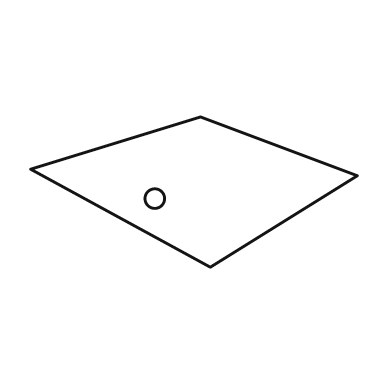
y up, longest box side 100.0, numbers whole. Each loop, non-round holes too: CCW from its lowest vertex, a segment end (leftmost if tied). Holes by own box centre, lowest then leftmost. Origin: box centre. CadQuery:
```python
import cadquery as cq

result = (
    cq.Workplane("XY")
    .moveTo(5.0, -23.0)
    .lineTo(50.0, 5.0)
    .lineTo(2.0, 23.0)
    .lineTo(-50.0, 7.0)
    .close()
    .moveTo(-12.0, -2.0)
    .circle(3.0)
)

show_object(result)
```